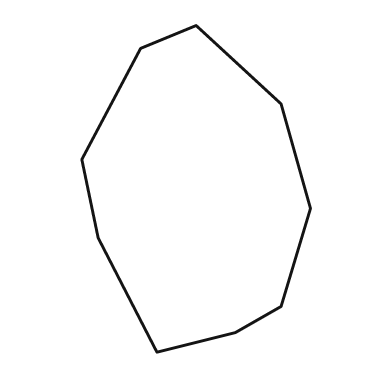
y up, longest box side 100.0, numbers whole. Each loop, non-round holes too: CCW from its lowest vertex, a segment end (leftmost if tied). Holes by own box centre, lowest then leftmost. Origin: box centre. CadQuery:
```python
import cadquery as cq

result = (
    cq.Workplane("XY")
    .moveTo(-12.0, -50.0)
    .lineTo(12.0, -44.0)
    .lineTo(26.0, -36.0)
    .lineTo(35.0, -6.0)
    .lineTo(26.0, 26.0)
    .lineTo(0.0, 50.0)
    .lineTo(-17.0, 43.0)
    .lineTo(-35.0, 9.0)
    .lineTo(-30.0, -15.0)
    .close()
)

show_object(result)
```